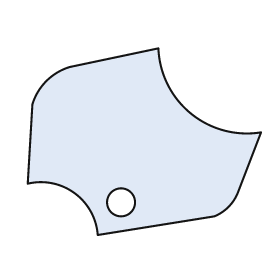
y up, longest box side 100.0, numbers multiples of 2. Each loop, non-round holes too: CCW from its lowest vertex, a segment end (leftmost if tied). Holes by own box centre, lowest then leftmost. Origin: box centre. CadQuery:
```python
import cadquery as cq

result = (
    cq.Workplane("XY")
    .moveTo(-20.0, -40.0)
    .lineTo(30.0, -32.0)
    .threePointArc((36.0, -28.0), (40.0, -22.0))
    .lineTo(50.0, 4.0)
    .threePointArc((20.0, 12.0), (6.0, 40.0))
    .lineTo(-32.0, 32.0)
    .threePointArc((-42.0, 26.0), (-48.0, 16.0))
    .lineTo(-50.0, -18.0)
    .threePointArc((-30.0, -22.0), (-20.0, -40.0))
    .close()
    .moveTo(-10.0, -26.0)
    .circle(6.0)
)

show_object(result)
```